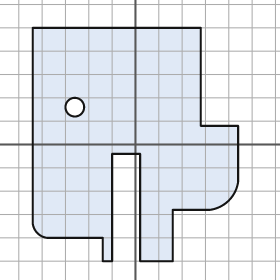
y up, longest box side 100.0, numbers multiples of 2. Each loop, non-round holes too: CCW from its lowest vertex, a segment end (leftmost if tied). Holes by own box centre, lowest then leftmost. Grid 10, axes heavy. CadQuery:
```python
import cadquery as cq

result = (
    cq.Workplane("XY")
    .moveTo(-14.0, -50.0)
    .lineTo(-10.0, -50.0)
    .lineTo(-10.0, -4.0)
    .lineTo(2.0, -4.0)
    .lineTo(2.0, -50.0)
    .lineTo(16.0, -50.0)
    .lineTo(16.0, -28.0)
    .lineTo(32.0, -28.0)
    .threePointArc((40.0, -24.0), (44.0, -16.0))
    .lineTo(44.0, 8.0)
    .lineTo(28.0, 8.0)
    .lineTo(28.0, 50.0)
    .lineTo(-44.0, 50.0)
    .lineTo(-44.0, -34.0)
    .threePointArc((-42.0, -38.0), (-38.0, -40.0))
    .lineTo(-14.0, -40.0)
    .close()
    .moveTo(-26.0, 16.0)
    .circle(4.0)
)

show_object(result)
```